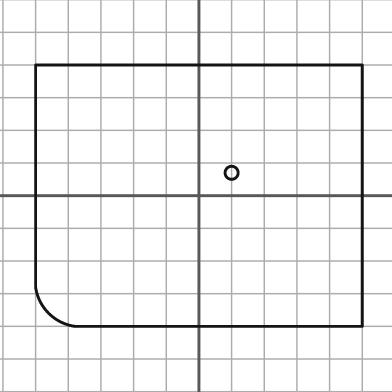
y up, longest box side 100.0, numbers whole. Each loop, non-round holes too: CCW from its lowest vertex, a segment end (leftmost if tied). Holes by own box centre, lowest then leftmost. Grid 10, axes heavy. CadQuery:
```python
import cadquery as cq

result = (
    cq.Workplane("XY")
    .moveTo(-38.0, -40.0)
    .lineTo(50.0, -40.0)
    .lineTo(50.0, 40.0)
    .lineTo(-50.0, 40.0)
    .lineTo(-50.0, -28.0)
    .threePointArc((-46.0, -36.0), (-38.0, -40.0))
    .close()
    .moveTo(10.0, 7.0)
    .circle(2.0)
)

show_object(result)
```